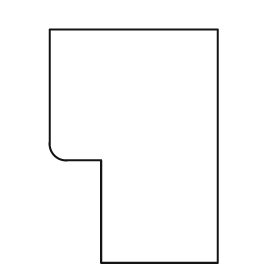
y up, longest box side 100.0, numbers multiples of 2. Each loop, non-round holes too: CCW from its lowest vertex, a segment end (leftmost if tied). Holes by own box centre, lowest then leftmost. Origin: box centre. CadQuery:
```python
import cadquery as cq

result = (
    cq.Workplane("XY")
    .moveTo(-14.0, -50.0)
    .lineTo(36.0, -50.0)
    .lineTo(36.0, 50.0)
    .lineTo(-36.0, 50.0)
    .lineTo(-36.0, 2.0)
    .threePointArc((-34.0, -4.0), (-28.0, -6.0))
    .lineTo(-14.0, -6.0)
    .close()
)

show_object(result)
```